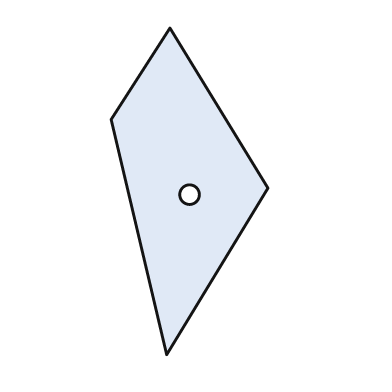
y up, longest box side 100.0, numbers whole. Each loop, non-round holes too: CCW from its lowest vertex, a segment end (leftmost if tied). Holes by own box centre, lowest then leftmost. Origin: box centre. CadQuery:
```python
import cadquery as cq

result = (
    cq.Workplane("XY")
    .moveTo(-7.0, -50.0)
    .lineTo(24.0, 1.0)
    .lineTo(-6.0, 50.0)
    .lineTo(-24.0, 22.0)
    .close()
    .moveTo(0.0, -1.0)
    .circle(3.0)
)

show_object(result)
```